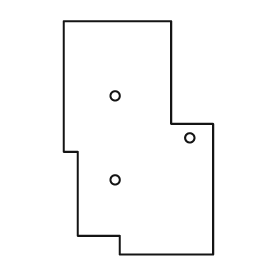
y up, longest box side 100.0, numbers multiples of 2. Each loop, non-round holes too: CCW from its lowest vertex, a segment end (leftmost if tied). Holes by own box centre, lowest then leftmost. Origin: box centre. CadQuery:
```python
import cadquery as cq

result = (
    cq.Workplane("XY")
    .moveTo(-8.0, -50.0)
    .lineTo(32.0, -50.0)
    .lineTo(32.0, 6.0)
    .lineTo(14.0, 6.0)
    .lineTo(14.0, 50.0)
    .lineTo(-32.0, 50.0)
    .lineTo(-32.0, -6.0)
    .lineTo(-26.0, -6.0)
    .lineTo(-26.0, -42.0)
    .lineTo(-8.0, -42.0)
    .close()
    .moveTo(-10.0, -18.0)
    .circle(2.0)
    .moveTo(22.0, 0.0)
    .circle(2.0)
    .moveTo(-10.0, 18.0)
    .circle(2.0)
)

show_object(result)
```